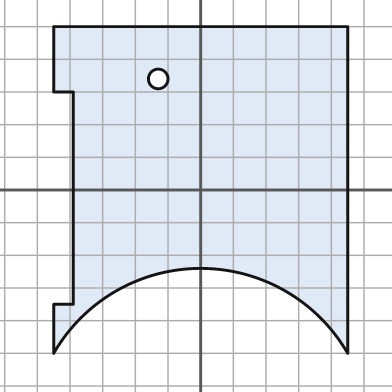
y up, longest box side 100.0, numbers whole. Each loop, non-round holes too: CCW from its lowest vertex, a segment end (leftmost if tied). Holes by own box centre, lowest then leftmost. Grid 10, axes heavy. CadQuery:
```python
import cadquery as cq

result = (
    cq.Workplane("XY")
    .moveTo(-45.0, -50.0)
    .threePointArc((0.0, -24.0), (45.0, -50.0))
    .lineTo(45.0, 50.0)
    .lineTo(-45.0, 50.0)
    .lineTo(-45.0, 30.0)
    .lineTo(-39.0, 30.0)
    .lineTo(-39.0, -35.0)
    .lineTo(-45.0, -35.0)
    .close()
    .moveTo(-13.0, 34.0)
    .circle(3.0)
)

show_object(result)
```